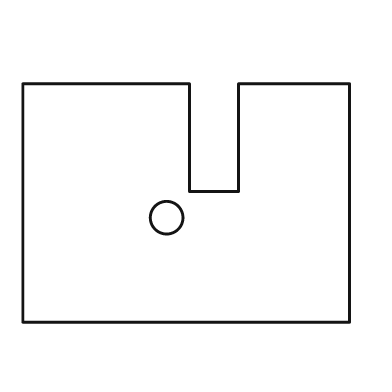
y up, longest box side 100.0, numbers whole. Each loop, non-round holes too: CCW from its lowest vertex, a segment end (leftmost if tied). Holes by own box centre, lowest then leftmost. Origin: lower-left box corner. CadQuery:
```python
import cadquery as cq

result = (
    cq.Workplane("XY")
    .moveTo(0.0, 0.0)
    .lineTo(100.0, 0.0)
    .lineTo(100.0, 73.0)
    .lineTo(66.0, 73.0)
    .lineTo(66.0, 40.0)
    .lineTo(51.0, 40.0)
    .lineTo(51.0, 73.0)
    .lineTo(0.0, 73.0)
    .close()
    .moveTo(44.0, 32.0)
    .circle(5.0)
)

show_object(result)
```